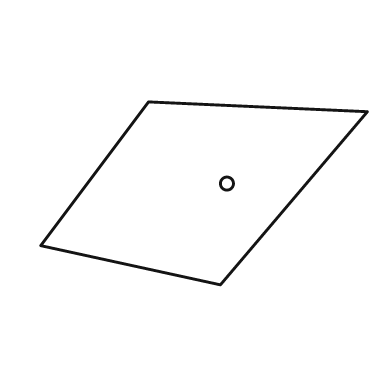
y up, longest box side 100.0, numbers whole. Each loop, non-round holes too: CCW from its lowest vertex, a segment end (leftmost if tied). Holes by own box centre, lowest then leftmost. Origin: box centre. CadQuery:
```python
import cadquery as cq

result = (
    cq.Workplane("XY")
    .moveTo(5.0, -28.0)
    .lineTo(50.0, 25.0)
    .lineTo(-17.0, 28.0)
    .lineTo(-50.0, -16.0)
    .close()
    .moveTo(7.0, 3.0)
    .circle(2.0)
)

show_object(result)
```